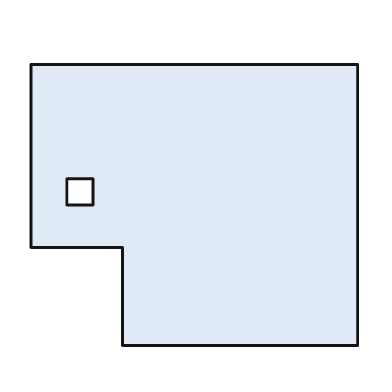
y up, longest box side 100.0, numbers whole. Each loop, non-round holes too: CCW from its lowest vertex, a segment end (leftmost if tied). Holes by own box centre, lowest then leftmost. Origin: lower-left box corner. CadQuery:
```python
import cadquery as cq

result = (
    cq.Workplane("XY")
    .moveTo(28.0, 0.0)
    .lineTo(100.0, 0.0)
    .lineTo(100.0, 86.0)
    .lineTo(0.0, 86.0)
    .lineTo(0.0, 30.0)
    .lineTo(28.0, 30.0)
    .close()
    .moveTo(11.0, 43.0)
    .lineTo(19.0, 43.0)
    .lineTo(19.0, 51.0)
    .lineTo(11.0, 51.0)
    .close()
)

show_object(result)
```